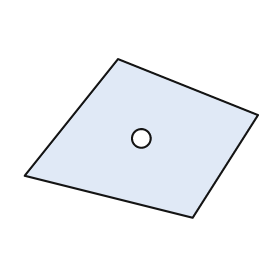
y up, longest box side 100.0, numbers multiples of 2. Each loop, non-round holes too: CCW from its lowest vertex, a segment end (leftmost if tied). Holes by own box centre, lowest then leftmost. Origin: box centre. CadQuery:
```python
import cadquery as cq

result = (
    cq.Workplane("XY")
    .moveTo(22.0, -34.0)
    .lineTo(50.0, 10.0)
    .lineTo(-10.0, 34.0)
    .lineTo(-50.0, -16.0)
    .close()
    .moveTo(0.0, 0.0)
    .circle(4.0)
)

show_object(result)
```